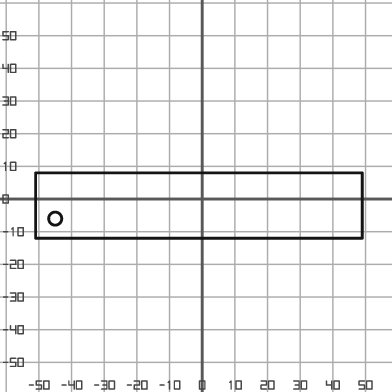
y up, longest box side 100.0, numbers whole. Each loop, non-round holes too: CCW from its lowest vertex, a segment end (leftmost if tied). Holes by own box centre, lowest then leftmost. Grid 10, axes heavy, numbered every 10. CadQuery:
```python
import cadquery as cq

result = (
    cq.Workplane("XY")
    .moveTo(-51.0, -12.0)
    .lineTo(49.0, -12.0)
    .lineTo(49.0, 8.0)
    .lineTo(-51.0, 8.0)
    .close()
    .moveTo(-45.0, -6.0)
    .circle(2.0)
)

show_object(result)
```